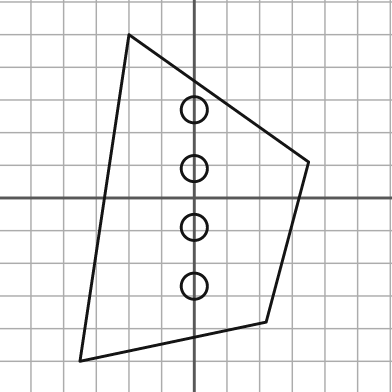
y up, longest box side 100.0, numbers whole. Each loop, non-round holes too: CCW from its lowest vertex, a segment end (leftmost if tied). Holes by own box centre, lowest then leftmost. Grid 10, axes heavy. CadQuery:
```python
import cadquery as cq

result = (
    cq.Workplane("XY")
    .moveTo(-35.0, -50.0)
    .lineTo(22.0, -38.0)
    .lineTo(35.0, 11.0)
    .lineTo(-20.0, 50.0)
    .close()
    .moveTo(0.0, -27.0)
    .circle(4.0)
    .moveTo(0.0, -9.0)
    .circle(4.0)
    .moveTo(0.0, 9.0)
    .circle(4.0)
    .moveTo(0.0, 27.0)
    .circle(4.0)
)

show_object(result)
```